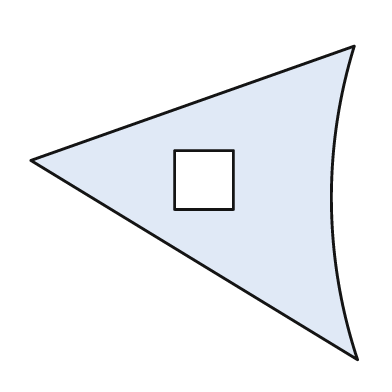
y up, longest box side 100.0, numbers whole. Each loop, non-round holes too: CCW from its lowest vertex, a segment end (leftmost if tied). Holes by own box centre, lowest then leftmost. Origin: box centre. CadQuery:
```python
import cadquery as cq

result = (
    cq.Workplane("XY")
    .moveTo(50.0, -48.0)
    .threePointArc((42.0, 0.0), (49.0, 48.0))
    .lineTo(-50.0, 13.0)
    .close()
    .moveTo(-6.0, -2.0)
    .lineTo(12.0, -2.0)
    .lineTo(12.0, 16.0)
    .lineTo(-6.0, 16.0)
    .close()
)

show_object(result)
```